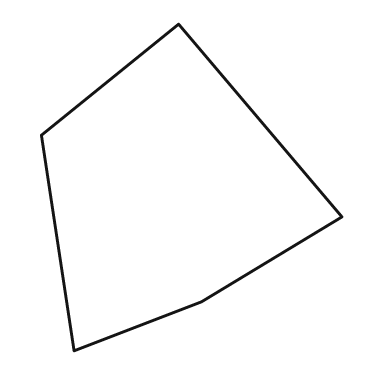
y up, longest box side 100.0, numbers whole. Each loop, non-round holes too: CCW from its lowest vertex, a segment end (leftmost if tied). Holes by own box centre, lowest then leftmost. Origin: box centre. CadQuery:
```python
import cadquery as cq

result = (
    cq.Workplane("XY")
    .moveTo(-36.0, -50.0)
    .lineTo(3.0, -35.0)
    .lineTo(46.0, -9.0)
    .lineTo(-4.0, 50.0)
    .lineTo(-46.0, 16.0)
    .close()
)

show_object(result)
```